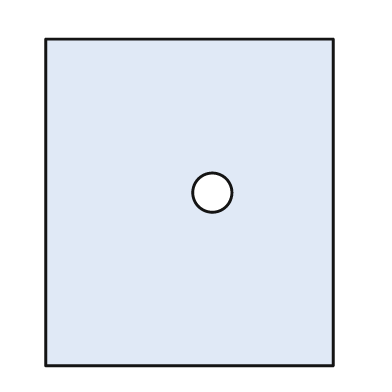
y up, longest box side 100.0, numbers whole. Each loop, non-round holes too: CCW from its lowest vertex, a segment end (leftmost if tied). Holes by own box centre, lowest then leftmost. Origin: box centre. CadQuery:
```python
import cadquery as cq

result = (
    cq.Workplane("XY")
    .moveTo(-44.0, -50.0)
    .lineTo(44.0, -50.0)
    .lineTo(44.0, 50.0)
    .lineTo(-44.0, 50.0)
    .close()
    .moveTo(7.0, 3.0)
    .circle(6.0)
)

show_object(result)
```